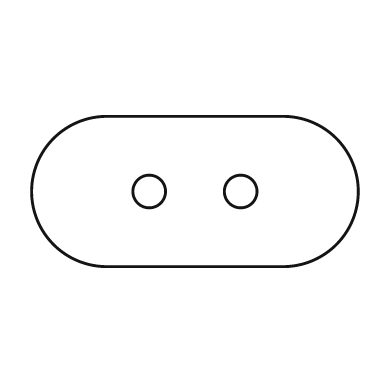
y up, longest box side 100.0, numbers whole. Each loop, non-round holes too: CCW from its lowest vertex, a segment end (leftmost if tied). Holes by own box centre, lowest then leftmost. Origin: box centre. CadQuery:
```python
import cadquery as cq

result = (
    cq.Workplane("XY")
    .moveTo(-27.0, -23.0)
    .lineTo(27.0, -23.0)
    .threePointArc((50.0, 0.0), (27.0, 23.0))
    .lineTo(-27.0, 23.0)
    .threePointArc((-50.0, 0.0), (-27.0, -23.0))
    .close()
    .moveTo(-14.0, 0.0)
    .circle(5.0)
    .moveTo(14.0, 0.0)
    .circle(5.0)
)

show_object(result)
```